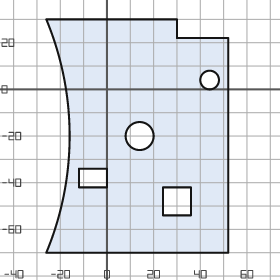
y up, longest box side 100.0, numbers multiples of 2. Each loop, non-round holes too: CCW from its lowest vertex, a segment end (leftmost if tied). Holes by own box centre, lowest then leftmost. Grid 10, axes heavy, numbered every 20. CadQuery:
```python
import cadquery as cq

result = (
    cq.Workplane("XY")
    .moveTo(-26.0, -70.0)
    .lineTo(52.0, -70.0)
    .lineTo(52.0, 22.0)
    .lineTo(30.0, 22.0)
    .lineTo(30.0, 30.0)
    .lineTo(-26.0, 30.0)
    .threePointArc((-16.0, -20.0), (-26.0, -70.0))
    .close()
    .moveTo(24.0, -54.0)
    .lineTo(36.0, -54.0)
    .lineTo(36.0, -42.0)
    .lineTo(24.0, -42.0)
    .close()
    .moveTo(-12.0, -42.0)
    .lineTo(0.0, -42.0)
    .lineTo(0.0, -34.0)
    .lineTo(-12.0, -34.0)
    .close()
    .moveTo(14.0, -20.0)
    .circle(6.0)
    .moveTo(44.0, 4.0)
    .circle(4.0)
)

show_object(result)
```